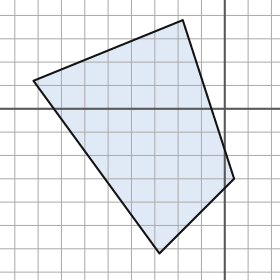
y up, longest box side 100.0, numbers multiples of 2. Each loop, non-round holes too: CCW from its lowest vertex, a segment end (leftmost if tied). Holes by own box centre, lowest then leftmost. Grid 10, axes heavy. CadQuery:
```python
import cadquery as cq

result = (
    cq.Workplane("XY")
    .moveTo(-28.0, -62.0)
    .lineTo(4.0, -30.0)
    .lineTo(-18.0, 38.0)
    .lineTo(-82.0, 12.0)
    .close()
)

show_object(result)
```